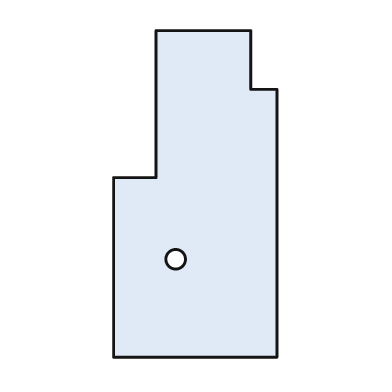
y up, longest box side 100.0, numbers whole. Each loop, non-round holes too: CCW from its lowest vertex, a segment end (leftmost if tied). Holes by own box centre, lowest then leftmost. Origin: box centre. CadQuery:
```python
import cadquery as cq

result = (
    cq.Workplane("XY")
    .moveTo(-25.0, -50.0)
    .lineTo(25.0, -50.0)
    .lineTo(25.0, 32.0)
    .lineTo(17.0, 32.0)
    .lineTo(17.0, 50.0)
    .lineTo(-12.0, 50.0)
    .lineTo(-12.0, 5.0)
    .lineTo(-25.0, 5.0)
    .close()
    .moveTo(-6.0, -20.0)
    .circle(3.0)
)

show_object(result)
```